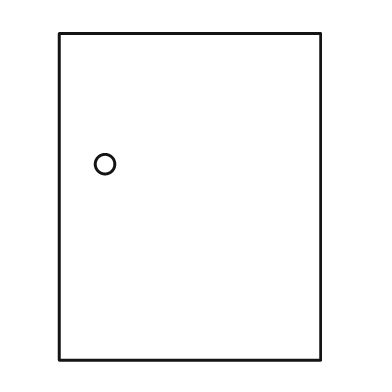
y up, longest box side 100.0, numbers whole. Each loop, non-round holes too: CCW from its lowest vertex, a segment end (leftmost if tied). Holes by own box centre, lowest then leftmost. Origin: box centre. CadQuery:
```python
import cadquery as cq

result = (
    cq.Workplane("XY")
    .moveTo(-40.0, -50.0)
    .lineTo(40.0, -50.0)
    .lineTo(40.0, 50.0)
    .lineTo(-40.0, 50.0)
    .close()
    .moveTo(-26.0, 10.0)
    .circle(3.0)
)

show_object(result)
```